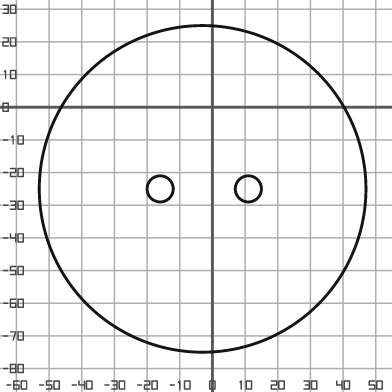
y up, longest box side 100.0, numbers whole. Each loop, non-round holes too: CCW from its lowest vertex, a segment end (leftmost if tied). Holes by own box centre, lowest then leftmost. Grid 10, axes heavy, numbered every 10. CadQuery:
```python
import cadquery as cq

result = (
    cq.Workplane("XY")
    .moveTo(-3.0, -25.0)
    .circle(50.0)
    .moveTo(-16.0, -25.0)
    .circle(4.0)
    .moveTo(11.0, -25.0)
    .circle(4.0)
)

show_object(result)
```